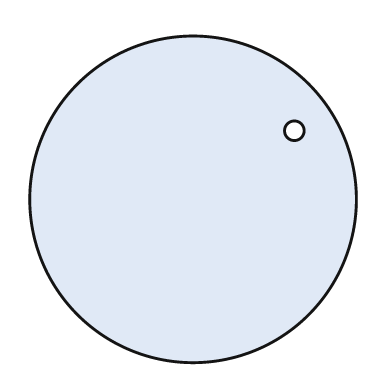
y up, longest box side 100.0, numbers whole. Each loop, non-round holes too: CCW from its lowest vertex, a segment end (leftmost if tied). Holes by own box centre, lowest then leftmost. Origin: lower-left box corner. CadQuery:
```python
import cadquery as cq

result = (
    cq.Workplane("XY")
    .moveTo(50.0, 50.0)
    .circle(50.0)
    .moveTo(81.0, 71.0)
    .circle(3.0)
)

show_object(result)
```